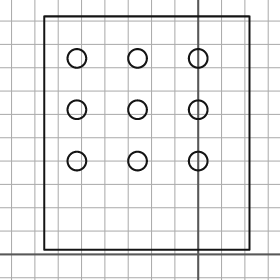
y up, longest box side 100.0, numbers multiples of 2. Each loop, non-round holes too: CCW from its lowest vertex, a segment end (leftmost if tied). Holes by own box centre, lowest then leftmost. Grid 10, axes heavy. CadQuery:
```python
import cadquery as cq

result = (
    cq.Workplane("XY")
    .moveTo(-66.0, 2.0)
    .lineTo(22.0, 2.0)
    .lineTo(22.0, 102.0)
    .lineTo(-66.0, 102.0)
    .close()
    .moveTo(-52.0, 40.0)
    .circle(4.0)
    .moveTo(-26.0, 40.0)
    .circle(4.0)
    .moveTo(0.0, 40.0)
    .circle(4.0)
    .moveTo(-52.0, 62.0)
    .circle(4.0)
    .moveTo(-26.0, 62.0)
    .circle(4.0)
    .moveTo(0.0, 62.0)
    .circle(4.0)
    .moveTo(-52.0, 84.0)
    .circle(4.0)
    .moveTo(-26.0, 84.0)
    .circle(4.0)
    .moveTo(0.0, 84.0)
    .circle(4.0)
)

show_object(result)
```